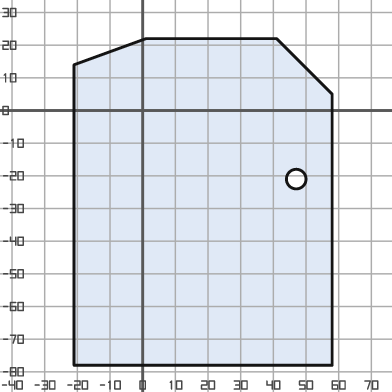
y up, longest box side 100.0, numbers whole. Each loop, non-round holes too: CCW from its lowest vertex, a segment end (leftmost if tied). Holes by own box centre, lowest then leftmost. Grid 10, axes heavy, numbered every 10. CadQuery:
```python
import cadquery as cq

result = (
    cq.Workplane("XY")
    .moveTo(-21.0, -78.0)
    .lineTo(58.0, -78.0)
    .lineTo(58.0, 5.0)
    .lineTo(41.0, 22.0)
    .lineTo(1.0, 22.0)
    .lineTo(-21.0, 14.0)
    .close()
    .moveTo(47.0, -21.0)
    .circle(3.0)
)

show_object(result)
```